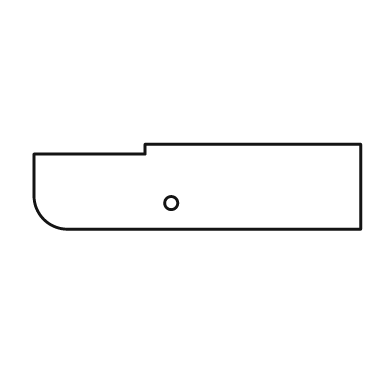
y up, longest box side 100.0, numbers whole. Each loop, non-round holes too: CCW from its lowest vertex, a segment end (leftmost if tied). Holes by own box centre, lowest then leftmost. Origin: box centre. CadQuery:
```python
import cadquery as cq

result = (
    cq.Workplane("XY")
    .moveTo(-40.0, -13.0)
    .lineTo(50.0, -13.0)
    .lineTo(50.0, 13.0)
    .lineTo(-16.0, 13.0)
    .lineTo(-16.0, 10.0)
    .lineTo(-50.0, 10.0)
    .lineTo(-50.0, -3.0)
    .threePointArc((-47.0, -10.0), (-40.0, -13.0))
    .close()
    .moveTo(-8.0, -5.0)
    .circle(2.0)
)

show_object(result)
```